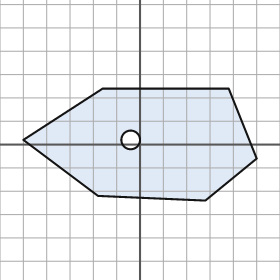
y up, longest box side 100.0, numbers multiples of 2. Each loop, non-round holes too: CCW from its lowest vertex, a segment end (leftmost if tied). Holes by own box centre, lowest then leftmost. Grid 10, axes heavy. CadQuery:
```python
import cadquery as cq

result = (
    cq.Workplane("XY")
    .moveTo(28.0, -24.0)
    .lineTo(50.0, -6.0)
    .lineTo(38.0, 24.0)
    .lineTo(-16.0, 24.0)
    .lineTo(-50.0, 2.0)
    .lineTo(-18.0, -22.0)
    .close()
    .moveTo(-4.0, 2.0)
    .circle(4.0)
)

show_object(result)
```